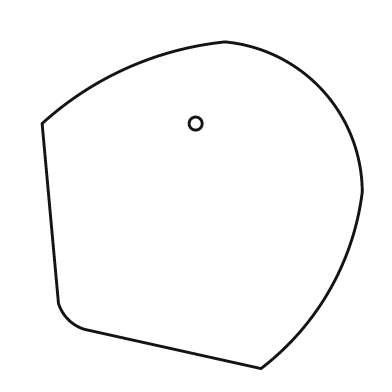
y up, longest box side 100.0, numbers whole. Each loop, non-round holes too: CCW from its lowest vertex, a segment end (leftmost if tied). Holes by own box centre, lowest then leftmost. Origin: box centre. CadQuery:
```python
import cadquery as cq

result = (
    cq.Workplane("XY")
    .moveTo(18.0, -50.0)
    .threePointArc((39.0, -26.0), (49.0, 4.0))
    .threePointArc((37.0, 35.0), (7.0, 50.0))
    .threePointArc((-23.0, 42.0), (-49.0, 25.0))
    .lineTo(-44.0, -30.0)
    .threePointArc((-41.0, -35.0), (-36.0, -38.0))
    .close()
    .moveTo(-2.0, 25.0)
    .circle(2.0)
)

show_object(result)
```